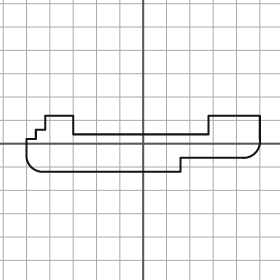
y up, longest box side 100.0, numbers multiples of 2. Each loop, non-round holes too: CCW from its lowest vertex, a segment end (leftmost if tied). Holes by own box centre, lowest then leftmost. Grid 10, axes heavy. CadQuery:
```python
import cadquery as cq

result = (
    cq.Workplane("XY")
    .moveTo(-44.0, -12.0)
    .lineTo(16.0, -12.0)
    .lineTo(16.0, -6.0)
    .lineTo(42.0, -6.0)
    .threePointArc((48.0, -4.0), (50.0, 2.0))
    .lineTo(50.0, 12.0)
    .lineTo(28.0, 12.0)
    .lineTo(28.0, 4.0)
    .lineTo(-30.0, 4.0)
    .lineTo(-30.0, 12.0)
    .lineTo(-42.0, 12.0)
    .lineTo(-42.0, 6.0)
    .lineTo(-46.0, 6.0)
    .lineTo(-46.0, 2.0)
    .lineTo(-50.0, 2.0)
    .lineTo(-50.0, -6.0)
    .threePointArc((-48.0, -10.0), (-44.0, -12.0))
    .close()
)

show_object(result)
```